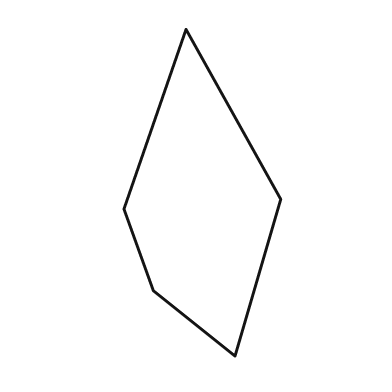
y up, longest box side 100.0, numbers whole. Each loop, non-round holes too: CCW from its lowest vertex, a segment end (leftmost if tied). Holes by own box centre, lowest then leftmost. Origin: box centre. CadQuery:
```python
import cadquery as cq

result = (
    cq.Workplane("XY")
    .moveTo(10.0, -50.0)
    .lineTo(24.0, -2.0)
    .lineTo(-5.0, 50.0)
    .lineTo(-24.0, -5.0)
    .lineTo(-15.0, -30.0)
    .close()
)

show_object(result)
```